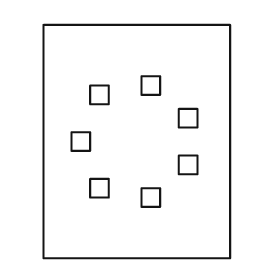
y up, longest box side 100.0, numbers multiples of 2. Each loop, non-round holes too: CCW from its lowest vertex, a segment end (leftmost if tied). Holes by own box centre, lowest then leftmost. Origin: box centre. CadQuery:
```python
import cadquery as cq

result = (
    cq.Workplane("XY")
    .moveTo(-40.0, -50.0)
    .lineTo(40.0, -50.0)
    .lineTo(40.0, 50.0)
    .lineTo(-40.0, 50.0)
    .close()
    .moveTo(2.0, -28.0)
    .lineTo(10.0, -28.0)
    .lineTo(10.0, -20.0)
    .lineTo(2.0, -20.0)
    .close()
    .moveTo(-20.0, -24.0)
    .lineTo(-12.0, -24.0)
    .lineTo(-12.0, -16.0)
    .lineTo(-20.0, -16.0)
    .close()
    .moveTo(18.0, -14.0)
    .lineTo(26.0, -14.0)
    .lineTo(26.0, -6.0)
    .lineTo(18.0, -6.0)
    .close()
    .moveTo(-28.0, -4.0)
    .lineTo(-20.0, -4.0)
    .lineTo(-20.0, 4.0)
    .lineTo(-28.0, 4.0)
    .close()
    .moveTo(18.0, 6.0)
    .lineTo(26.0, 6.0)
    .lineTo(26.0, 14.0)
    .lineTo(18.0, 14.0)
    .close()
    .moveTo(-20.0, 16.0)
    .lineTo(-12.0, 16.0)
    .lineTo(-12.0, 24.0)
    .lineTo(-20.0, 24.0)
    .close()
    .moveTo(2.0, 20.0)
    .lineTo(10.0, 20.0)
    .lineTo(10.0, 28.0)
    .lineTo(2.0, 28.0)
    .close()
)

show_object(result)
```